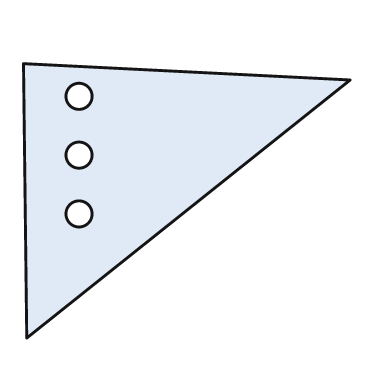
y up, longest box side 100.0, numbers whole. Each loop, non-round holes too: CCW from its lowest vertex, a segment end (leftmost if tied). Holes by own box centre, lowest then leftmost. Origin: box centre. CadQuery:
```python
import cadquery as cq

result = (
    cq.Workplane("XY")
    .moveTo(-49.0, -42.0)
    .lineTo(50.0, 37.0)
    .lineTo(-50.0, 42.0)
    .close()
    .moveTo(-33.0, -4.0)
    .circle(4.0)
    .moveTo(-33.0, 14.0)
    .circle(4.0)
    .moveTo(-33.0, 32.0)
    .circle(4.0)
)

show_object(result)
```